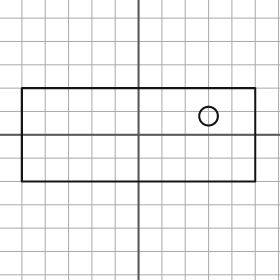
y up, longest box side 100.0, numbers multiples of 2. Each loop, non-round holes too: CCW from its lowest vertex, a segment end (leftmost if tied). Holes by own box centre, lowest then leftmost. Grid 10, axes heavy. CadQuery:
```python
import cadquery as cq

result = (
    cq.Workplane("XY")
    .moveTo(-50.0, -20.0)
    .lineTo(50.0, -20.0)
    .lineTo(50.0, 20.0)
    .lineTo(-50.0, 20.0)
    .close()
    .moveTo(30.0, 8.0)
    .circle(4.0)
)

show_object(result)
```